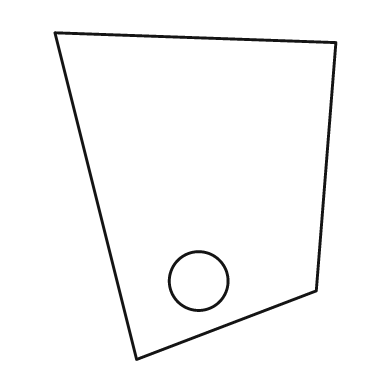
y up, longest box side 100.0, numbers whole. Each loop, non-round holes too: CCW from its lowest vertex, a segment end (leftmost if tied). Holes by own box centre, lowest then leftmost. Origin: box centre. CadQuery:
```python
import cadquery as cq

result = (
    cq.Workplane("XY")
    .moveTo(-18.0, -50.0)
    .lineTo(37.0, -29.0)
    .lineTo(43.0, 47.0)
    .lineTo(-43.0, 50.0)
    .close()
    .moveTo(1.0, -26.0)
    .circle(9.0)
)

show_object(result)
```